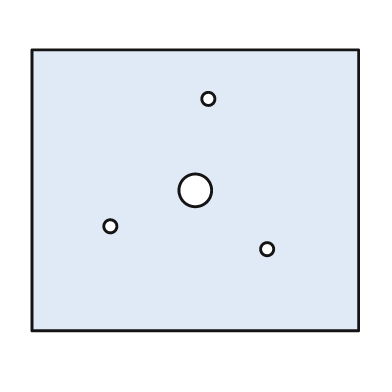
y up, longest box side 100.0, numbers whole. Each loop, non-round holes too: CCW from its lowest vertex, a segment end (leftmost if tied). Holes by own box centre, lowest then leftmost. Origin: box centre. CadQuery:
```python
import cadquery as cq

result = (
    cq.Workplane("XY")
    .moveTo(-50.0, -43.0)
    .lineTo(50.0, -43.0)
    .lineTo(50.0, 43.0)
    .lineTo(-50.0, 43.0)
    .close()
    .moveTo(22.0, -18.0)
    .circle(2.0)
    .moveTo(-26.0, -11.0)
    .circle(2.0)
    .moveTo(0.0, 0.0)
    .circle(5.0)
    .moveTo(4.0, 28.0)
    .circle(2.0)
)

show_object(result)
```